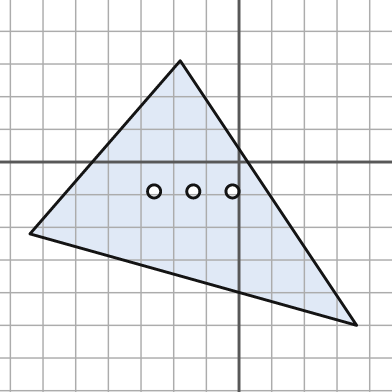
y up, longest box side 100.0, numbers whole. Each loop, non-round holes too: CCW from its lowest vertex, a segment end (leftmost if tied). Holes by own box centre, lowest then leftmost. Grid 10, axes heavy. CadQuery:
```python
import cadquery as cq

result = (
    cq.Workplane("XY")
    .moveTo(36.0, -50.0)
    .lineTo(-18.0, 31.0)
    .lineTo(-64.0, -22.0)
    .close()
    .moveTo(-26.0, -9.0)
    .circle(2.0)
    .moveTo(-14.0, -9.0)
    .circle(2.0)
    .moveTo(-2.0, -9.0)
    .circle(2.0)
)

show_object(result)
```